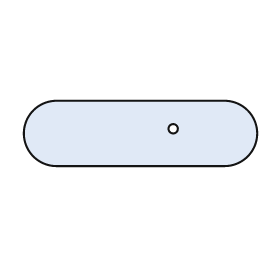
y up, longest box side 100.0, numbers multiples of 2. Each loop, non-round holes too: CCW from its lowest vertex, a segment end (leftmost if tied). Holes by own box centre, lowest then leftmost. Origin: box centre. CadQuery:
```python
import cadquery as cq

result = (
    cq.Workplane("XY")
    .moveTo(-36.0, -14.0)
    .lineTo(36.0, -14.0)
    .threePointArc((50.0, 0.0), (36.0, 14.0))
    .lineTo(-36.0, 14.0)
    .threePointArc((-50.0, 0.0), (-36.0, -14.0))
    .close()
    .moveTo(14.0, 2.0)
    .circle(2.0)
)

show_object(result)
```